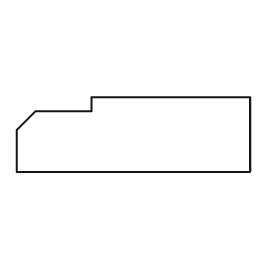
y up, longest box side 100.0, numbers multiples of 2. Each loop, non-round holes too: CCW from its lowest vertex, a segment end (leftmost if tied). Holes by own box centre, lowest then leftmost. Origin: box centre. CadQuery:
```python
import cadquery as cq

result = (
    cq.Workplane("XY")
    .moveTo(-50.0, -16.0)
    .lineTo(50.0, -16.0)
    .lineTo(50.0, 16.0)
    .lineTo(-18.0, 16.0)
    .lineTo(-18.0, 10.0)
    .lineTo(-42.0, 10.0)
    .lineTo(-50.0, 2.0)
    .close()
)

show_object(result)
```